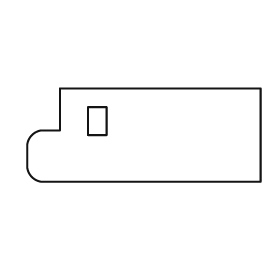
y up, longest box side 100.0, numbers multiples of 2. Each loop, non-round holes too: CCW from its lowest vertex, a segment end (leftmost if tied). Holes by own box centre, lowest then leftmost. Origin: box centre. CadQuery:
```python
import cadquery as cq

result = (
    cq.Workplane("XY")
    .moveTo(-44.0, -20.0)
    .lineTo(50.0, -20.0)
    .lineTo(50.0, 20.0)
    .lineTo(-36.0, 20.0)
    .lineTo(-36.0, 2.0)
    .lineTo(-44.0, 2.0)
    .threePointArc((-48.0, 0.0), (-50.0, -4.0))
    .lineTo(-50.0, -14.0)
    .threePointArc((-48.0, -18.0), (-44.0, -20.0))
    .close()
    .moveTo(-24.0, 0.0)
    .lineTo(-16.0, 0.0)
    .lineTo(-16.0, 12.0)
    .lineTo(-24.0, 12.0)
    .close()
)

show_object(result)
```